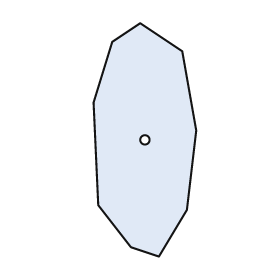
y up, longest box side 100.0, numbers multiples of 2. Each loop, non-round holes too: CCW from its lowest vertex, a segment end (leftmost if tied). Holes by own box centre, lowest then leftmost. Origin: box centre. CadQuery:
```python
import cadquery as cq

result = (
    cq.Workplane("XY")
    .moveTo(6.0, -50.0)
    .lineTo(18.0, -30.0)
    .lineTo(22.0, 4.0)
    .lineTo(16.0, 38.0)
    .lineTo(-2.0, 50.0)
    .lineTo(-14.0, 42.0)
    .lineTo(-22.0, 16.0)
    .lineTo(-20.0, -28.0)
    .lineTo(-6.0, -46.0)
    .close()
    .moveTo(0.0, 0.0)
    .circle(2.0)
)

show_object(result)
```